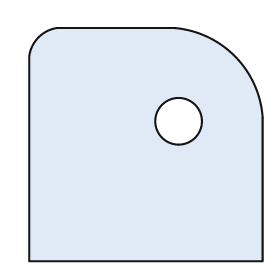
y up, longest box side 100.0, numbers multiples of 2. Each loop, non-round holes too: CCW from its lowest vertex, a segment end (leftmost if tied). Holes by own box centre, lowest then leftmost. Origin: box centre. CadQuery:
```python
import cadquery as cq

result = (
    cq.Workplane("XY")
    .moveTo(-50.0, -50.0)
    .lineTo(50.0, -50.0)
    .lineTo(50.0, 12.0)
    .threePointArc((38.0, 38.0), (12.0, 50.0))
    .lineTo(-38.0, 50.0)
    .threePointArc((-46.0, 46.0), (-50.0, 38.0))
    .close()
    .moveTo(14.0, 10.0)
    .circle(10.0)
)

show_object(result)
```